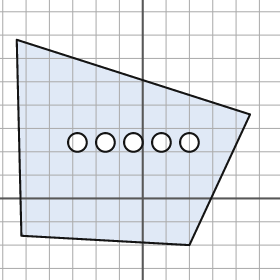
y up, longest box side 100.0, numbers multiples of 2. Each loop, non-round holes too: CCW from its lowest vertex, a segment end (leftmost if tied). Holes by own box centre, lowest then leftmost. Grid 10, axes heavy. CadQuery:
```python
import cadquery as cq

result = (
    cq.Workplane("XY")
    .moveTo(20.0, -20.0)
    .lineTo(46.0, 36.0)
    .lineTo(-54.0, 68.0)
    .lineTo(-52.0, -16.0)
    .close()
    .moveTo(-28.0, 24.0)
    .circle(4.0)
    .moveTo(-16.0, 24.0)
    .circle(4.0)
    .moveTo(-4.0, 24.0)
    .circle(4.0)
    .moveTo(8.0, 24.0)
    .circle(4.0)
    .moveTo(20.0, 24.0)
    .circle(4.0)
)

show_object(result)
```